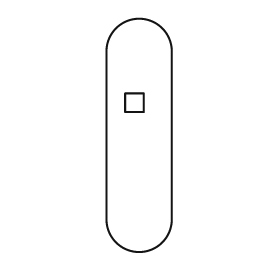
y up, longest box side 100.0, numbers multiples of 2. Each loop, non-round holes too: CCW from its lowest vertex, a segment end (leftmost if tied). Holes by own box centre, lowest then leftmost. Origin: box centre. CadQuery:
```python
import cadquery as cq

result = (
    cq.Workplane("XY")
    .moveTo(-14.0, -36.0)
    .threePointArc((0.0, -50.0), (14.0, -36.0))
    .lineTo(14.0, 36.0)
    .threePointArc((0.0, 50.0), (-14.0, 36.0))
    .close()
    .moveTo(-6.0, 10.0)
    .lineTo(2.0, 10.0)
    .lineTo(2.0, 18.0)
    .lineTo(-6.0, 18.0)
    .close()
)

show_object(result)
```